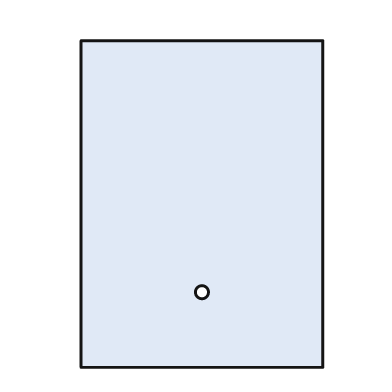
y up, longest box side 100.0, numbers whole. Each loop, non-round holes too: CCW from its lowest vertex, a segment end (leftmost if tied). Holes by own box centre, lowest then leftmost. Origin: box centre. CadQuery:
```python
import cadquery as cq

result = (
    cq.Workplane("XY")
    .moveTo(-37.0, -50.0)
    .lineTo(37.0, -50.0)
    .lineTo(37.0, 50.0)
    .lineTo(-37.0, 50.0)
    .close()
    .moveTo(0.0, -27.0)
    .circle(2.0)
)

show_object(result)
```